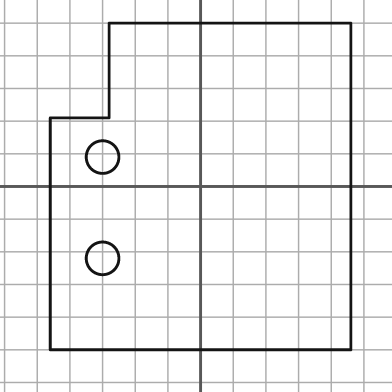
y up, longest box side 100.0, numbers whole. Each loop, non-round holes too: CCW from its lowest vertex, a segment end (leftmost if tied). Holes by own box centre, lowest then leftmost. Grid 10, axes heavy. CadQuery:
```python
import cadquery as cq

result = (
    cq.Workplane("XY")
    .moveTo(-46.0, -50.0)
    .lineTo(46.0, -50.0)
    .lineTo(46.0, 50.0)
    .lineTo(-28.0, 50.0)
    .lineTo(-28.0, 21.0)
    .lineTo(-46.0, 21.0)
    .close()
    .moveTo(-30.0, -22.0)
    .circle(5.0)
    .moveTo(-30.0, 9.0)
    .circle(5.0)
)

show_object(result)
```